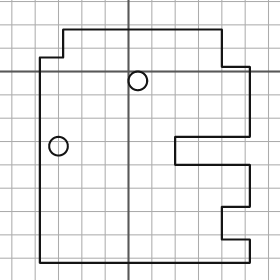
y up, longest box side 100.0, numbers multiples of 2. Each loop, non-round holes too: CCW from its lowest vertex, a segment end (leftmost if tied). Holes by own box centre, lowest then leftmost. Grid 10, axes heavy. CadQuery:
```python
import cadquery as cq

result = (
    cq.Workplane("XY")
    .moveTo(-38.0, -82.0)
    .lineTo(52.0, -82.0)
    .lineTo(52.0, -72.0)
    .lineTo(40.0, -72.0)
    .lineTo(40.0, -58.0)
    .lineTo(52.0, -58.0)
    .lineTo(52.0, -40.0)
    .lineTo(20.0, -40.0)
    .lineTo(20.0, -28.0)
    .lineTo(52.0, -28.0)
    .lineTo(52.0, 2.0)
    .lineTo(40.0, 2.0)
    .lineTo(40.0, 18.0)
    .lineTo(-28.0, 18.0)
    .lineTo(-28.0, 6.0)
    .lineTo(-38.0, 6.0)
    .close()
    .moveTo(-30.0, -32.0)
    .circle(4.0)
    .moveTo(4.0, -4.0)
    .circle(4.0)
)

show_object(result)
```